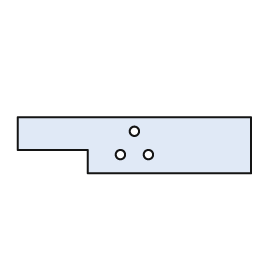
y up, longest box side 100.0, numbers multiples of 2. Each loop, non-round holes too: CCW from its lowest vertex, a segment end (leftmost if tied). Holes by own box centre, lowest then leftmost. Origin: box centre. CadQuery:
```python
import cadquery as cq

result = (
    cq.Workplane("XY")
    .moveTo(-20.0, -12.0)
    .lineTo(50.0, -12.0)
    .lineTo(50.0, 12.0)
    .lineTo(-50.0, 12.0)
    .lineTo(-50.0, -2.0)
    .lineTo(-20.0, -2.0)
    .close()
    .moveTo(-6.0, -4.0)
    .circle(2.0)
    .moveTo(6.0, -4.0)
    .circle(2.0)
    .moveTo(0.0, 6.0)
    .circle(2.0)
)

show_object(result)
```